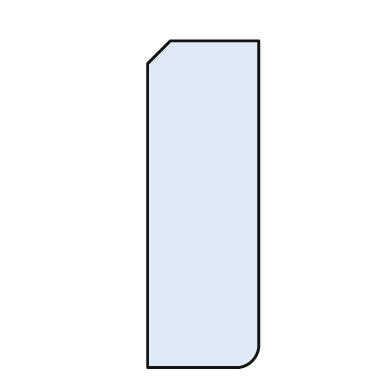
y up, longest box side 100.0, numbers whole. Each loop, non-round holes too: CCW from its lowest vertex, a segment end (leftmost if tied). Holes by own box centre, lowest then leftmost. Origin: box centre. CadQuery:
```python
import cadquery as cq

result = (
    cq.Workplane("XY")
    .moveTo(-17.0, -50.0)
    .lineTo(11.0, -50.0)
    .threePointArc((15.0, -48.0), (17.0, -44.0))
    .lineTo(17.0, 50.0)
    .lineTo(-10.0, 50.0)
    .lineTo(-17.0, 43.0)
    .close()
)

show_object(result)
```